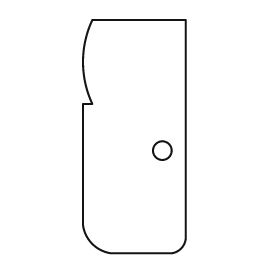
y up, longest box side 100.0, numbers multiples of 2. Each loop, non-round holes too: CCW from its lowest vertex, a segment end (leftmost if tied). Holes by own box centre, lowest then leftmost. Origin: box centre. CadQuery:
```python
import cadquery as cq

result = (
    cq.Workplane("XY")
    .moveTo(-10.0, -50.0)
    .lineTo(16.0, -50.0)
    .threePointArc((20.0, -48.0), (22.0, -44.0))
    .lineTo(22.0, 50.0)
    .lineTo(-18.0, 50.0)
    .threePointArc((-22.0, 32.0), (-18.0, 14.0))
    .lineTo(-22.0, 14.0)
    .lineTo(-22.0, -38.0)
    .threePointArc((-18.0, -46.0), (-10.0, -50.0))
    .close()
    .moveTo(12.0, -6.0)
    .circle(4.0)
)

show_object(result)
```